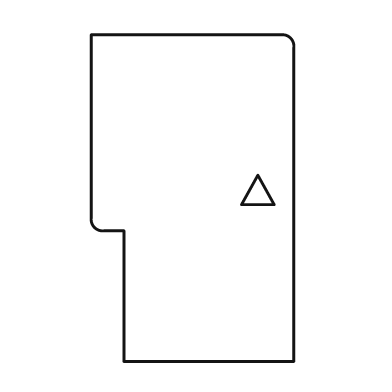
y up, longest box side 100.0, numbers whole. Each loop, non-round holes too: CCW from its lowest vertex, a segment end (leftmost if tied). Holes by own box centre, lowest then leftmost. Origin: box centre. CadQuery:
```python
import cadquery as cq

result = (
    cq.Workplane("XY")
    .moveTo(-21.0, -50.0)
    .lineTo(31.0, -50.0)
    .lineTo(31.0, 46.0)
    .threePointArc((30.0, 49.0), (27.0, 50.0))
    .lineTo(-31.0, 50.0)
    .lineTo(-31.0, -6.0)
    .threePointArc((-30.0, -9.0), (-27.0, -10.0))
    .lineTo(-21.0, -10.0)
    .close()
    .moveTo(15.0, -2.0)
    .lineTo(25.0, -2.0)
    .lineTo(20.0, 7.0)
    .close()
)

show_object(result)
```